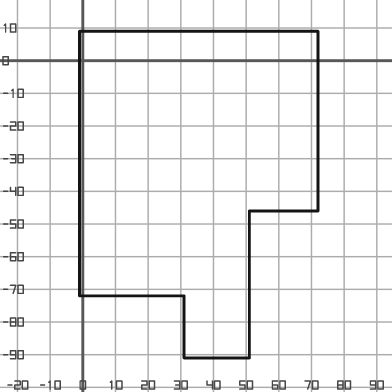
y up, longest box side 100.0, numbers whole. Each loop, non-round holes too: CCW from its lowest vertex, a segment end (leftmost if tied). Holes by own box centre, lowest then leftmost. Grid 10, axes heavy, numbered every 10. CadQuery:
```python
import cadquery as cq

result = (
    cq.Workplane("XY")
    .moveTo(31.0, -91.0)
    .lineTo(51.0, -91.0)
    .lineTo(51.0, -46.0)
    .lineTo(72.0, -46.0)
    .lineTo(72.0, 9.0)
    .lineTo(-1.0, 9.0)
    .lineTo(-1.0, -72.0)
    .lineTo(31.0, -72.0)
    .close()
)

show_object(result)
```